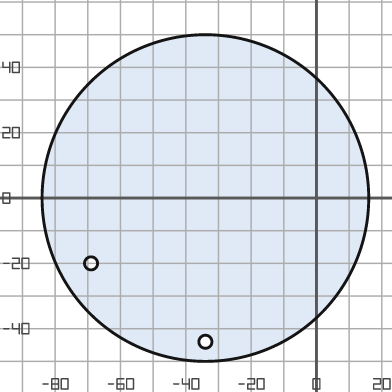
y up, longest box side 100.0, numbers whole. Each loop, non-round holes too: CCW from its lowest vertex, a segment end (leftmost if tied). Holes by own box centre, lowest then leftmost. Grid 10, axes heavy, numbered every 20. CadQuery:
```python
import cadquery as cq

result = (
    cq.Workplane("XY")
    .moveTo(-34.0, 0.0)
    .circle(50.0)
    .moveTo(-34.0, -44.0)
    .circle(2.0)
    .moveTo(-69.0, -20.0)
    .circle(2.0)
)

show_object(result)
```